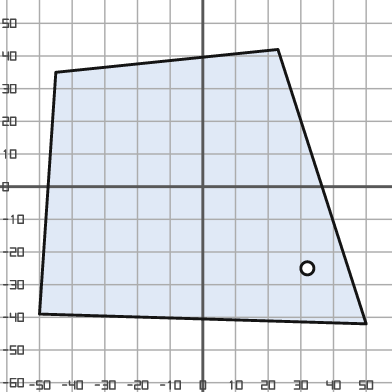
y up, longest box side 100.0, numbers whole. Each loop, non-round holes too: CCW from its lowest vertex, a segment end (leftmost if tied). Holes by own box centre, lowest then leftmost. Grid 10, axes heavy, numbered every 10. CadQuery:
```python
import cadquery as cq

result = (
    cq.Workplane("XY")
    .moveTo(50.0, -42.0)
    .lineTo(23.0, 42.0)
    .lineTo(-45.0, 35.0)
    .lineTo(-50.0, -39.0)
    .close()
    .moveTo(32.0, -25.0)
    .circle(2.0)
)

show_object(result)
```